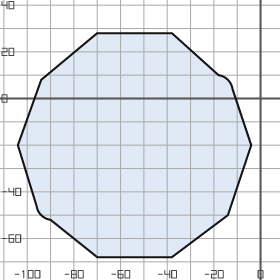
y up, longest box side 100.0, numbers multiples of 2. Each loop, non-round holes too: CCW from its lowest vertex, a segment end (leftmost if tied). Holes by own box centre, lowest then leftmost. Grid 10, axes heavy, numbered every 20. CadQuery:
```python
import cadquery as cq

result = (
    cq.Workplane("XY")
    .moveTo(-70.0, -68.0)
    .lineTo(-38.0, -68.0)
    .lineTo(-14.0, -50.0)
    .lineTo(-4.0, -20.0)
    .lineTo(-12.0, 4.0)
    .threePointArc((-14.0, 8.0), (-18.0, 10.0))
    .lineTo(-38.0, 28.0)
    .lineTo(-70.0, 28.0)
    .lineTo(-94.0, 8.0)
    .lineTo(-104.0, -20.0)
    .lineTo(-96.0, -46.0)
    .threePointArc((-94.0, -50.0), (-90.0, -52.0))
    .close()
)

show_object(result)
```